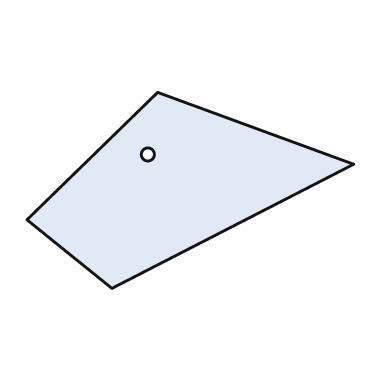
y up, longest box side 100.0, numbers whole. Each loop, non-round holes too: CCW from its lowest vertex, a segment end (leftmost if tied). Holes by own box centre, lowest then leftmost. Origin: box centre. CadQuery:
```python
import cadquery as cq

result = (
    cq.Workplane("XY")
    .moveTo(-24.0, -30.0)
    .lineTo(50.0, 8.0)
    .lineTo(-10.0, 30.0)
    .lineTo(-50.0, -9.0)
    .close()
    .moveTo(-13.0, 11.0)
    .circle(2.0)
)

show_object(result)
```